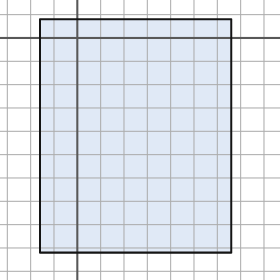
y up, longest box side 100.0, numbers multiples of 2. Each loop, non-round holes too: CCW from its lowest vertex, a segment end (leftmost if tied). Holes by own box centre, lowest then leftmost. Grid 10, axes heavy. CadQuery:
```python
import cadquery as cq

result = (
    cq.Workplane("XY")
    .moveTo(-16.0, -92.0)
    .lineTo(66.0, -92.0)
    .lineTo(66.0, 8.0)
    .lineTo(-16.0, 8.0)
    .close()
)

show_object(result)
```